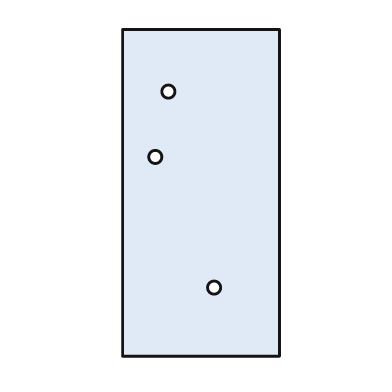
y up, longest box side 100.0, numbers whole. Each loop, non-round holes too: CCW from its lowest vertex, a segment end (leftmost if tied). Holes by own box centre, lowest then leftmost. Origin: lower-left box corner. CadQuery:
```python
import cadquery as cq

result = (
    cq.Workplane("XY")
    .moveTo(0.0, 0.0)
    .lineTo(48.0, 0.0)
    .lineTo(48.0, 100.0)
    .lineTo(0.0, 100.0)
    .close()
    .moveTo(28.0, 21.0)
    .circle(2.0)
    .moveTo(10.0, 61.0)
    .circle(2.0)
    .moveTo(14.0, 81.0)
    .circle(2.0)
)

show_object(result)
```